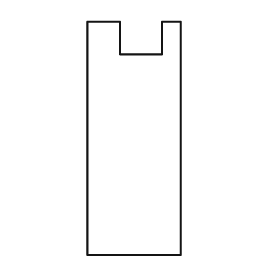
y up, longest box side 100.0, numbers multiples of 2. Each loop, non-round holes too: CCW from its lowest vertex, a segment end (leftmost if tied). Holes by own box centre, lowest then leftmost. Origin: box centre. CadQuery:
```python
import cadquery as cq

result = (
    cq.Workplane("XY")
    .moveTo(-20.0, -50.0)
    .lineTo(20.0, -50.0)
    .lineTo(20.0, 50.0)
    .lineTo(12.0, 50.0)
    .lineTo(12.0, 36.0)
    .lineTo(-6.0, 36.0)
    .lineTo(-6.0, 50.0)
    .lineTo(-20.0, 50.0)
    .close()
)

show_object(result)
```